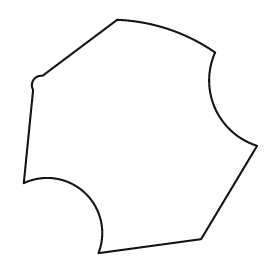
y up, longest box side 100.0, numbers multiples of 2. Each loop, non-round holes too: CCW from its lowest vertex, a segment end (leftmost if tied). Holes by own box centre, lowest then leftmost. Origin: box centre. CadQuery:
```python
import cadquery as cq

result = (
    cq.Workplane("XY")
    .moveTo(-18.0, -50.0)
    .lineTo(26.0, -44.0)
    .lineTo(50.0, -4.0)
    .threePointArc((32.0, 12.0), (32.0, 36.0))
    .threePointArc((12.0, 46.0), (-10.0, 50.0))
    .lineTo(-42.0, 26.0)
    .threePointArc((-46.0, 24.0), (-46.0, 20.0))
    .lineTo(-50.0, -20.0)
    .threePointArc((-24.0, -24.0), (-18.0, -50.0))
    .close()
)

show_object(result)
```